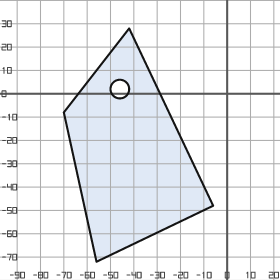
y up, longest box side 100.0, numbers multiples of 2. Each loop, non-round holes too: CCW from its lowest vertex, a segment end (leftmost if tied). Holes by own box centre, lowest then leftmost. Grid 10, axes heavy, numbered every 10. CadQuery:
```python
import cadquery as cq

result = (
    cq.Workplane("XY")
    .moveTo(-56.0, -72.0)
    .lineTo(-6.0, -48.0)
    .lineTo(-42.0, 28.0)
    .lineTo(-70.0, -8.0)
    .close()
    .moveTo(-46.0, 2.0)
    .circle(4.0)
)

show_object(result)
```